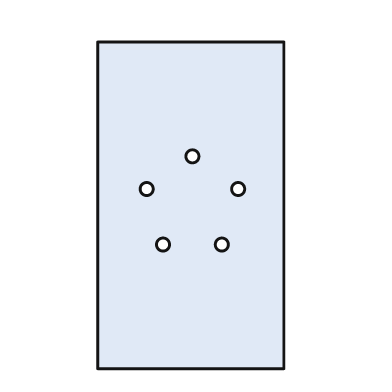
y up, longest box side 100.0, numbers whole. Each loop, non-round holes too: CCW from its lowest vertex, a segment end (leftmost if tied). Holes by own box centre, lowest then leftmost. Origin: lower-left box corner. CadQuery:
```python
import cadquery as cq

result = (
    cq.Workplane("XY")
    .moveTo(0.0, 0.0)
    .lineTo(57.0, 0.0)
    .lineTo(57.0, 100.0)
    .lineTo(0.0, 100.0)
    .close()
    .moveTo(20.0, 38.0)
    .circle(2.0)
    .moveTo(38.0, 38.0)
    .circle(2.0)
    .moveTo(15.0, 55.0)
    .circle(2.0)
    .moveTo(43.0, 55.0)
    .circle(2.0)
    .moveTo(29.0, 65.0)
    .circle(2.0)
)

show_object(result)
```